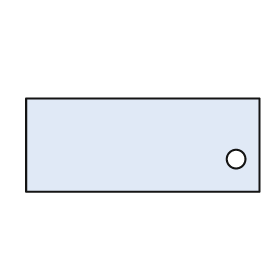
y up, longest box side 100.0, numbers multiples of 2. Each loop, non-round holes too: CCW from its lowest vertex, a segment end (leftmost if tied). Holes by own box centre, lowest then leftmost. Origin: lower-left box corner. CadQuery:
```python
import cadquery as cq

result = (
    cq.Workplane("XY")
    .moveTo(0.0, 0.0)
    .lineTo(100.0, 0.0)
    .lineTo(100.0, 40.0)
    .lineTo(0.0, 40.0)
    .close()
    .moveTo(90.0, 14.0)
    .circle(4.0)
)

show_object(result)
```